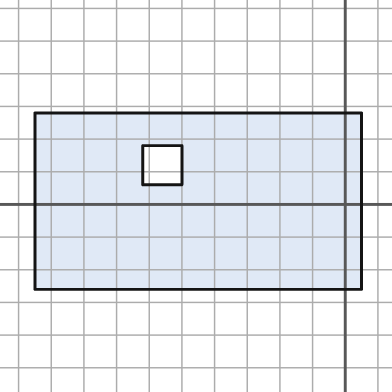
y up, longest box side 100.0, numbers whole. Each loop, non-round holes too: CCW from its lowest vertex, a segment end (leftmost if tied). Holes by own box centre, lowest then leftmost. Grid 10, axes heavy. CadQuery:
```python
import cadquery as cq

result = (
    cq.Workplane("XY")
    .moveTo(-95.0, -26.0)
    .lineTo(5.0, -26.0)
    .lineTo(5.0, 28.0)
    .lineTo(-95.0, 28.0)
    .close()
    .moveTo(-62.0, 6.0)
    .lineTo(-50.0, 6.0)
    .lineTo(-50.0, 18.0)
    .lineTo(-62.0, 18.0)
    .close()
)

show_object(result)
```